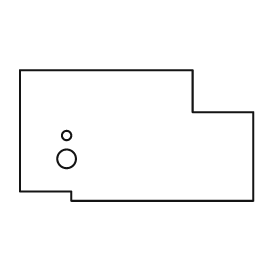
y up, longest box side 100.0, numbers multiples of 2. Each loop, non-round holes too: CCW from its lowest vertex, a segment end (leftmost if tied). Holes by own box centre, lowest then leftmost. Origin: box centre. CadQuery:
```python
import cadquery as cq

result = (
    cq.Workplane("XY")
    .moveTo(-28.0, -28.0)
    .lineTo(50.0, -28.0)
    .lineTo(50.0, 10.0)
    .lineTo(24.0, 10.0)
    .lineTo(24.0, 28.0)
    .lineTo(-50.0, 28.0)
    .lineTo(-50.0, -24.0)
    .lineTo(-28.0, -24.0)
    .close()
    .moveTo(-30.0, -10.0)
    .circle(4.0)
    .moveTo(-30.0, 0.0)
    .circle(2.0)
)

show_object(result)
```